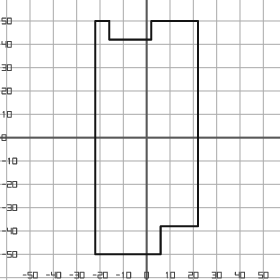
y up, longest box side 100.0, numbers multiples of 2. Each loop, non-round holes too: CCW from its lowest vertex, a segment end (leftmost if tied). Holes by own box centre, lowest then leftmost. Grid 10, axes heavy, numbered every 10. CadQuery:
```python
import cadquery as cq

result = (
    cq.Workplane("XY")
    .moveTo(-22.0, -50.0)
    .lineTo(6.0, -50.0)
    .lineTo(6.0, -38.0)
    .lineTo(22.0, -38.0)
    .lineTo(22.0, 50.0)
    .lineTo(2.0, 50.0)
    .lineTo(2.0, 42.0)
    .lineTo(-16.0, 42.0)
    .lineTo(-16.0, 50.0)
    .lineTo(-22.0, 50.0)
    .close()
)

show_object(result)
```